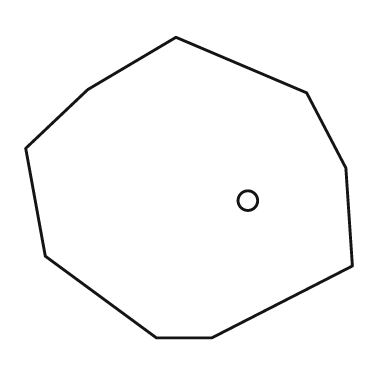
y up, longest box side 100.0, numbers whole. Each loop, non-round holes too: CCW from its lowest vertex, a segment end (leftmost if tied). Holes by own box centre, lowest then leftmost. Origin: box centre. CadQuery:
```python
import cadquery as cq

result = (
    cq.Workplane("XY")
    .moveTo(-10.0, -46.0)
    .lineTo(7.0, -46.0)
    .lineTo(50.0, -24.0)
    .lineTo(48.0, 6.0)
    .lineTo(36.0, 29.0)
    .lineTo(-4.0, 46.0)
    .lineTo(-31.0, 30.0)
    .lineTo(-50.0, 12.0)
    .lineTo(-44.0, -21.0)
    .close()
    .moveTo(18.0, -4.0)
    .circle(3.0)
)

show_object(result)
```